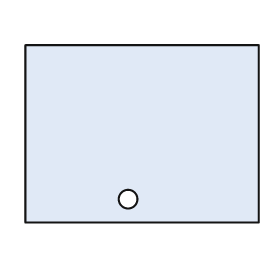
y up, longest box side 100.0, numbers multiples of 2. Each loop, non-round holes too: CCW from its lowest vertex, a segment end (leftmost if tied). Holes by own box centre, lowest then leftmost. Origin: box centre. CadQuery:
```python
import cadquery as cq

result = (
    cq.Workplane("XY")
    .moveTo(-50.0, -38.0)
    .lineTo(50.0, -38.0)
    .lineTo(50.0, 38.0)
    .lineTo(-50.0, 38.0)
    .close()
    .moveTo(-6.0, -28.0)
    .circle(4.0)
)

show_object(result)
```